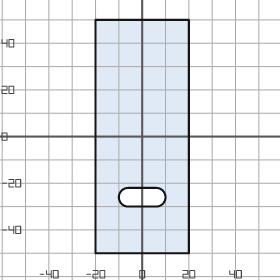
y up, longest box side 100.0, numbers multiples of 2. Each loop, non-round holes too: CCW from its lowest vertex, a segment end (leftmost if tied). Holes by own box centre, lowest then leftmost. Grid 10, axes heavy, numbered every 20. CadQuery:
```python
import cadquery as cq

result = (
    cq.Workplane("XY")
    .moveTo(-20.0, -50.0)
    .lineTo(20.0, -50.0)
    .lineTo(20.0, 50.0)
    .lineTo(-20.0, 50.0)
    .close()
    .moveTo(-6.0, -30.0)
    .lineTo(6.0, -30.0)
    .threePointArc((10.0, -26.0), (6.0, -22.0))
    .lineTo(-6.0, -22.0)
    .threePointArc((-10.0, -26.0), (-6.0, -30.0))
    .close()
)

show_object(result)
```